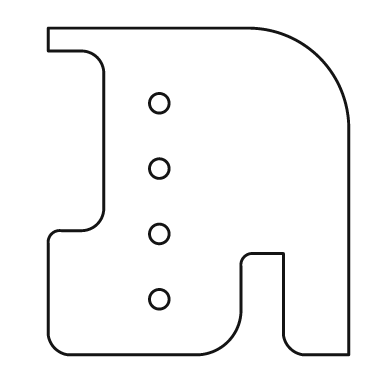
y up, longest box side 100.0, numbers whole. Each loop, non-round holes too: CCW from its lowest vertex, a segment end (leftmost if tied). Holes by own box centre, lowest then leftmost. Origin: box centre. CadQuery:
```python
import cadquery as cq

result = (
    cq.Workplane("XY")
    .moveTo(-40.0, -50.0)
    .lineTo(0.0, -50.0)
    .threePointArc((9.0, -46.0), (13.0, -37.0))
    .lineTo(13.0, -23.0)
    .threePointArc((14.0, -20.0), (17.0, -19.0))
    .lineTo(26.0, -19.0)
    .lineTo(26.0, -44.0)
    .threePointArc((28.0, -48.0), (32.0, -50.0))
    .lineTo(46.0, -50.0)
    .lineTo(46.0, 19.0)
    .threePointArc((37.0, 41.0), (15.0, 50.0))
    .lineTo(-46.0, 50.0)
    .lineTo(-46.0, 43.0)
    .lineTo(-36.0, 43.0)
    .threePointArc((-31.0, 41.0), (-29.0, 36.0))
    .lineTo(-29.0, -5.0)
    .threePointArc((-31.0, -10.0), (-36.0, -12.0))
    .lineTo(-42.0, -12.0)
    .threePointArc((-45.0, -13.0), (-46.0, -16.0))
    .lineTo(-46.0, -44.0)
    .threePointArc((-44.0, -48.0), (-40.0, -50.0))
    .close()
    .moveTo(-12.0, -33.0)
    .circle(3.0)
    .moveTo(-12.0, -13.0)
    .circle(3.0)
    .moveTo(-12.0, 7.0)
    .circle(3.0)
    .moveTo(-12.0, 27.0)
    .circle(3.0)
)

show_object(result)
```